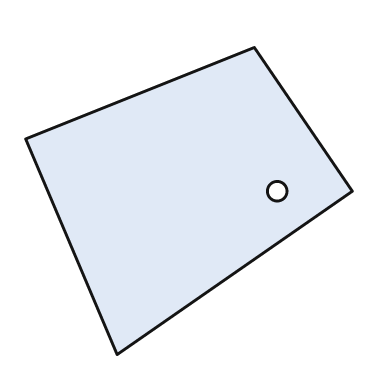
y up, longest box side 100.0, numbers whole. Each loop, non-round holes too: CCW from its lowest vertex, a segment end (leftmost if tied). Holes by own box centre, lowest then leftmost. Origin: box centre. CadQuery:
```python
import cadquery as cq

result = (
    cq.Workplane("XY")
    .moveTo(-22.0, -47.0)
    .lineTo(50.0, 3.0)
    .lineTo(20.0, 47.0)
    .lineTo(-50.0, 19.0)
    .close()
    .moveTo(27.0, 3.0)
    .circle(3.0)
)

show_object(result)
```